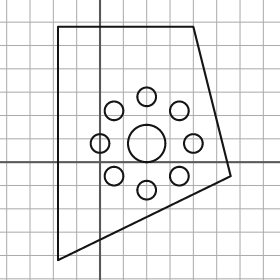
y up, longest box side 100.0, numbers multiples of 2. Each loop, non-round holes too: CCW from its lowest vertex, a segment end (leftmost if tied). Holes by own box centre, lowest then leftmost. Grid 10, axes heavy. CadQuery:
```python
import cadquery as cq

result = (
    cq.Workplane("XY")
    .moveTo(-18.0, -42.0)
    .lineTo(56.0, -6.0)
    .lineTo(40.0, 58.0)
    .lineTo(-18.0, 58.0)
    .close()
    .moveTo(20.0, -12.0)
    .circle(4.0)
    .moveTo(6.0, -6.0)
    .circle(4.0)
    .moveTo(34.0, -6.0)
    .circle(4.0)
    .moveTo(0.0, 8.0)
    .circle(4.0)
    .moveTo(20.0, 8.0)
    .circle(8.0)
    .moveTo(40.0, 8.0)
    .circle(4.0)
    .moveTo(6.0, 22.0)
    .circle(4.0)
    .moveTo(34.0, 22.0)
    .circle(4.0)
    .moveTo(20.0, 28.0)
    .circle(4.0)
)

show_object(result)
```